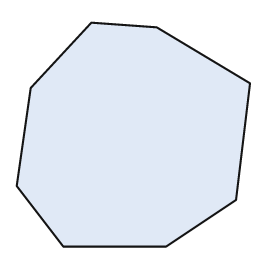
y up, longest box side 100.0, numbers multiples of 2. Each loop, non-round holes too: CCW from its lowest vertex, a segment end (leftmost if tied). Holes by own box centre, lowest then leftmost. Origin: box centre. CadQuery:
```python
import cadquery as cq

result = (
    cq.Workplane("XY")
    .moveTo(-30.0, -48.0)
    .lineTo(14.0, -48.0)
    .lineTo(44.0, -28.0)
    .lineTo(50.0, 22.0)
    .lineTo(10.0, 46.0)
    .lineTo(-18.0, 48.0)
    .lineTo(-44.0, 20.0)
    .lineTo(-50.0, -22.0)
    .close()
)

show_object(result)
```